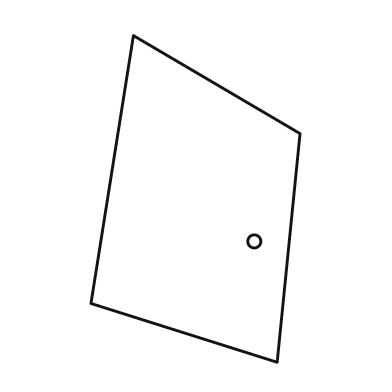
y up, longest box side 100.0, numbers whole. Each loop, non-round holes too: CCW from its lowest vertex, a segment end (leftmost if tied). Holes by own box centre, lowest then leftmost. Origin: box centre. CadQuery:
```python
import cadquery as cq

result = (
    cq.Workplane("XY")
    .moveTo(25.0, -50.0)
    .lineTo(32.0, 20.0)
    .lineTo(-19.0, 50.0)
    .lineTo(-32.0, -32.0)
    .close()
    .moveTo(18.0, -13.0)
    .circle(2.0)
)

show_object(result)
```